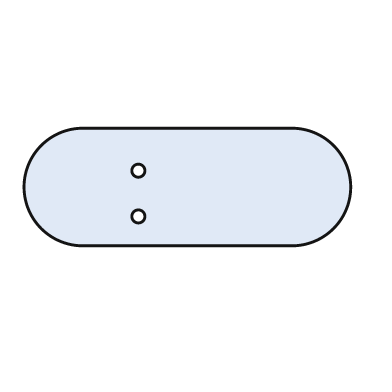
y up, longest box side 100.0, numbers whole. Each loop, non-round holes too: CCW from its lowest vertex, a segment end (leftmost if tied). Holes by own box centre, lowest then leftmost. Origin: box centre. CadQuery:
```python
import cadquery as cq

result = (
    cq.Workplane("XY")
    .moveTo(-32.0, -18.0)
    .lineTo(32.0, -18.0)
    .threePointArc((50.0, 0.0), (32.0, 18.0))
    .lineTo(-32.0, 18.0)
    .threePointArc((-50.0, 0.0), (-32.0, -18.0))
    .close()
    .moveTo(-15.0, -9.0)
    .circle(2.0)
    .moveTo(-15.0, 5.0)
    .circle(2.0)
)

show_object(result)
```